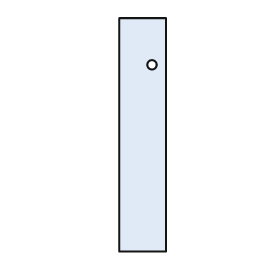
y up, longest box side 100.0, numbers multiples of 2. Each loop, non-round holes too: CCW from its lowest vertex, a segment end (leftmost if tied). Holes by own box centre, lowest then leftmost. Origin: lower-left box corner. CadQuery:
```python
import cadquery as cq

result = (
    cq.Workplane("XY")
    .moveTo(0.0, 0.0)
    .lineTo(20.0, 0.0)
    .lineTo(20.0, 100.0)
    .lineTo(0.0, 100.0)
    .close()
    .moveTo(14.0, 80.0)
    .circle(2.0)
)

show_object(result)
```